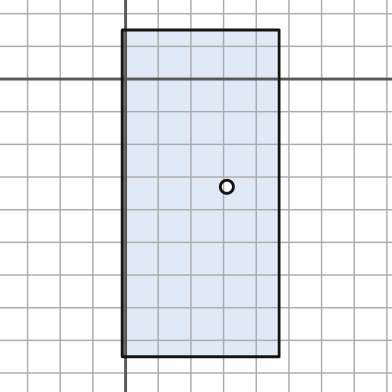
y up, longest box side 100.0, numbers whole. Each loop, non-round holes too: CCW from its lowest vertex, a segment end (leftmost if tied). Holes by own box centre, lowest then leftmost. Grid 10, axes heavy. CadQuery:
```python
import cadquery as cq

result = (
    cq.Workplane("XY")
    .moveTo(-1.0, -85.0)
    .lineTo(47.0, -85.0)
    .lineTo(47.0, 15.0)
    .lineTo(-1.0, 15.0)
    .close()
    .moveTo(31.0, -33.0)
    .circle(2.0)
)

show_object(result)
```